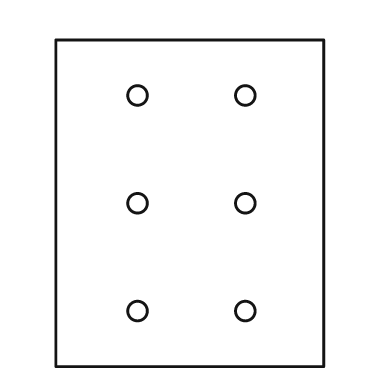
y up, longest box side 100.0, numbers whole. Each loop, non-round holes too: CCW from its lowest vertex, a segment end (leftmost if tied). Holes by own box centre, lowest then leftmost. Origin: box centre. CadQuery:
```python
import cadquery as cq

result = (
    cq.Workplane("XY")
    .moveTo(-41.0, -50.0)
    .lineTo(41.0, -50.0)
    .lineTo(41.0, 50.0)
    .lineTo(-41.0, 50.0)
    .close()
    .moveTo(-16.0, -33.0)
    .circle(3.0)
    .moveTo(17.0, -33.0)
    .circle(3.0)
    .moveTo(-16.0, 0.0)
    .circle(3.0)
    .moveTo(17.0, 0.0)
    .circle(3.0)
    .moveTo(-16.0, 33.0)
    .circle(3.0)
    .moveTo(17.0, 33.0)
    .circle(3.0)
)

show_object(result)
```